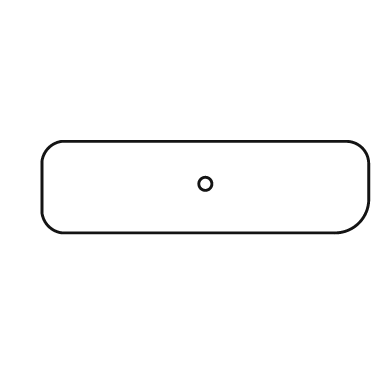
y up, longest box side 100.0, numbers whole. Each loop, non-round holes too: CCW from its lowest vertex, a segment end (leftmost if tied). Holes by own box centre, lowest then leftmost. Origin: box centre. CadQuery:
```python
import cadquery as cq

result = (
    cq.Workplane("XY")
    .moveTo(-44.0, -14.0)
    .lineTo(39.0, -14.0)
    .threePointArc((47.0, -11.0), (50.0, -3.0))
    .lineTo(50.0, 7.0)
    .threePointArc((48.0, 12.0), (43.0, 14.0))
    .lineTo(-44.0, 14.0)
    .threePointArc((-48.0, 12.0), (-50.0, 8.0))
    .lineTo(-50.0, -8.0)
    .threePointArc((-48.0, -12.0), (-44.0, -14.0))
    .close()
    .moveTo(0.0, 1.0)
    .circle(2.0)
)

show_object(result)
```